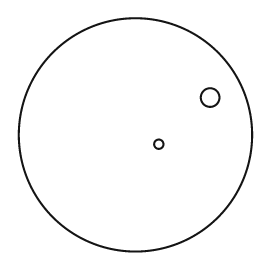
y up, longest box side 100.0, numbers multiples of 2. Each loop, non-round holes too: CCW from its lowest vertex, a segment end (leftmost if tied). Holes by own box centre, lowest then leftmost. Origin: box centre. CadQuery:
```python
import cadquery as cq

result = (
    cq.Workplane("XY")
    .moveTo(0.0, 0.0)
    .circle(50.0)
    .moveTo(10.0, -4.0)
    .circle(2.0)
    .moveTo(32.0, 16.0)
    .circle(4.0)
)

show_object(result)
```